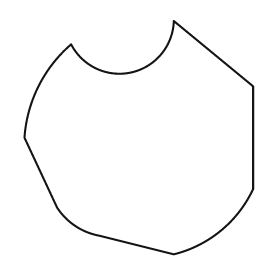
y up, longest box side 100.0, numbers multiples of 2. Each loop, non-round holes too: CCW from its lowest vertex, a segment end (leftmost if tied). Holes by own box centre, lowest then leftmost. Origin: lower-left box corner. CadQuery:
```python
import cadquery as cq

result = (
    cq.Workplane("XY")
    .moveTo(64.0, 0.0)
    .threePointArc((84.0, 10.0), (98.0, 28.0))
    .lineTo(98.0, 72.0)
    .lineTo(64.0, 100.0)
    .threePointArc((46.0, 78.0), (20.0, 90.0))
    .threePointArc((6.0, 72.0), (0.0, 50.0))
    .lineTo(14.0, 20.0)
    .threePointArc((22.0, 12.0), (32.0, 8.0))
    .close()
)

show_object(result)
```